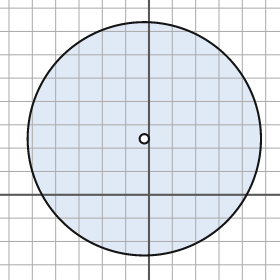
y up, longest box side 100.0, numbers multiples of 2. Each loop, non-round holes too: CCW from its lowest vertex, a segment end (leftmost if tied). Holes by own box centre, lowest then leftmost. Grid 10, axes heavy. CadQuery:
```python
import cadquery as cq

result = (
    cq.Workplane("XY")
    .moveTo(-2.0, 24.0)
    .circle(50.0)
    .moveTo(-2.0, 24.0)
    .circle(2.0)
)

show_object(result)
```